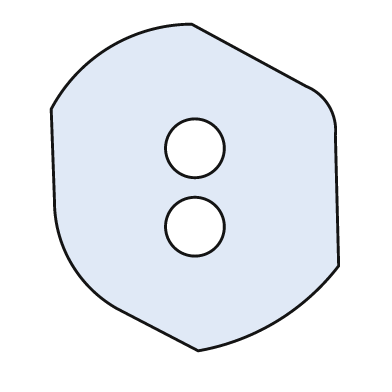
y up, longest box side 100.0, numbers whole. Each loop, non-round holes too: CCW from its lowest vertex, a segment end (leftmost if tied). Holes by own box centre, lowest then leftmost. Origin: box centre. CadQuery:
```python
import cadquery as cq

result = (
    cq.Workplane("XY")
    .moveTo(1.0, -50.0)
    .threePointArc((25.0, -41.0), (44.0, -24.0))
    .lineTo(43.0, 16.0)
    .threePointArc((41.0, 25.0), (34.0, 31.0))
    .lineTo(-1.0, 50.0)
    .threePointArc((-26.0, 43.0), (-44.0, 24.0))
    .lineTo(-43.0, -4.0)
    .threePointArc((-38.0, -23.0), (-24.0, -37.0))
    .close()
    .moveTo(0.0, -12.0)
    .circle(9.0)
    .moveTo(0.0, 12.0)
    .circle(9.0)
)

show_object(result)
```